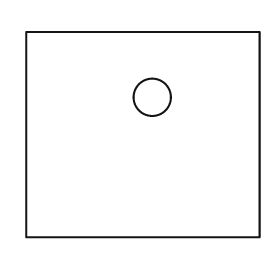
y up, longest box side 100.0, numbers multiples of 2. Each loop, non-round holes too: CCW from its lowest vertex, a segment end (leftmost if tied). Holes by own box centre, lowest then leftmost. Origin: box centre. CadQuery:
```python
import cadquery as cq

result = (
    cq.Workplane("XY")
    .moveTo(-50.0, -44.0)
    .lineTo(50.0, -44.0)
    .lineTo(50.0, 44.0)
    .lineTo(-50.0, 44.0)
    .close()
    .moveTo(4.0, 16.0)
    .circle(8.0)
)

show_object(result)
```